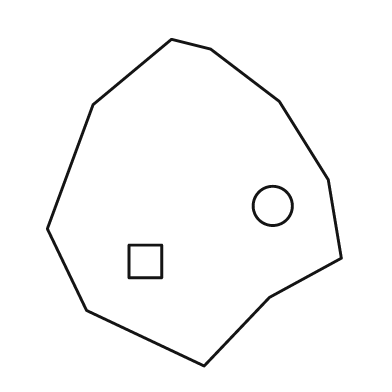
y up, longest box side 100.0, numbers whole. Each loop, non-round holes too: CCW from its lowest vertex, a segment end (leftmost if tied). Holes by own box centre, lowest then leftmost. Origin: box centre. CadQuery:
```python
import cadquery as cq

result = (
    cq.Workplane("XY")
    .moveTo(3.0, -50.0)
    .lineTo(23.0, -29.0)
    .lineTo(45.0, -17.0)
    .lineTo(41.0, 7.0)
    .lineTo(26.0, 31.0)
    .lineTo(5.0, 47.0)
    .lineTo(-7.0, 50.0)
    .lineTo(-31.0, 30.0)
    .lineTo(-45.0, -8.0)
    .lineTo(-33.0, -33.0)
    .close()
    .moveTo(-20.0, -23.0)
    .lineTo(-10.0, -23.0)
    .lineTo(-10.0, -13.0)
    .lineTo(-20.0, -13.0)
    .close()
    .moveTo(24.0, -1.0)
    .circle(6.0)
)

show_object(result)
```